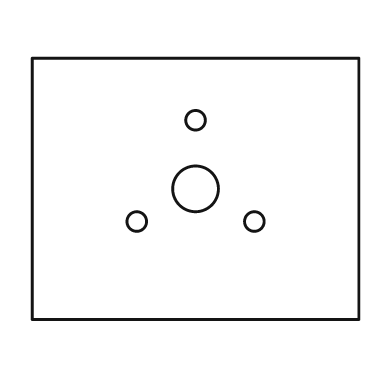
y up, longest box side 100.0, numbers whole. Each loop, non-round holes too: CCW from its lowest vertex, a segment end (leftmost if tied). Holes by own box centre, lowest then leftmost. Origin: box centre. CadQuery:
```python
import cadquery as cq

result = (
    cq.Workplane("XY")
    .moveTo(-50.0, -40.0)
    .lineTo(50.0, -40.0)
    .lineTo(50.0, 40.0)
    .lineTo(-50.0, 40.0)
    .close()
    .moveTo(-18.0, -10.0)
    .circle(3.0)
    .moveTo(18.0, -10.0)
    .circle(3.0)
    .moveTo(0.0, 0.0)
    .circle(7.0)
    .moveTo(0.0, 21.0)
    .circle(3.0)
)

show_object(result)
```